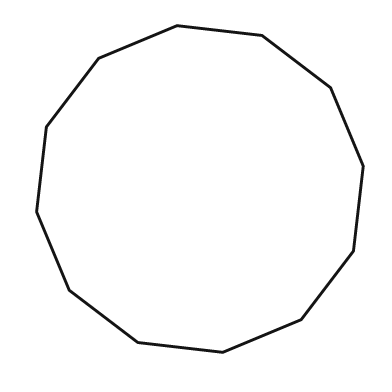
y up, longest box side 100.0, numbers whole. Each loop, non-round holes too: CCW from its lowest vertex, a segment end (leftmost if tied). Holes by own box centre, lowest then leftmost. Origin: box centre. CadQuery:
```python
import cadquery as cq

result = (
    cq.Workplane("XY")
    .moveTo(7.0, -50.0)
    .lineTo(31.0, -40.0)
    .lineTo(47.0, -19.0)
    .lineTo(50.0, 7.0)
    .lineTo(40.0, 31.0)
    .lineTo(19.0, 47.0)
    .lineTo(-7.0, 50.0)
    .lineTo(-31.0, 40.0)
    .lineTo(-47.0, 19.0)
    .lineTo(-50.0, -7.0)
    .lineTo(-40.0, -31.0)
    .lineTo(-19.0, -47.0)
    .close()
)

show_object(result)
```